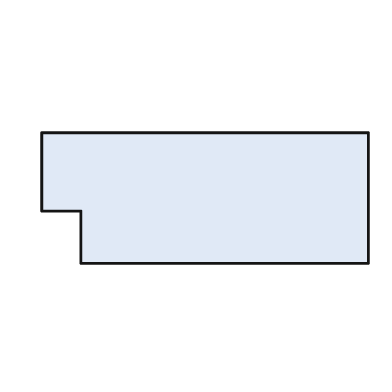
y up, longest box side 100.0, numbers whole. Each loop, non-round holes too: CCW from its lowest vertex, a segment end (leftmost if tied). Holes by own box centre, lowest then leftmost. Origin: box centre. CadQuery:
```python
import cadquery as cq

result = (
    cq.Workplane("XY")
    .moveTo(-38.0, -20.0)
    .lineTo(50.0, -20.0)
    .lineTo(50.0, 20.0)
    .lineTo(-50.0, 20.0)
    .lineTo(-50.0, -4.0)
    .lineTo(-38.0, -4.0)
    .close()
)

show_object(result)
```